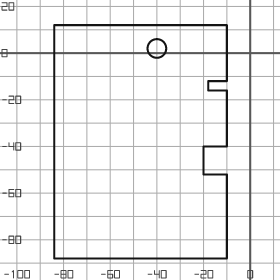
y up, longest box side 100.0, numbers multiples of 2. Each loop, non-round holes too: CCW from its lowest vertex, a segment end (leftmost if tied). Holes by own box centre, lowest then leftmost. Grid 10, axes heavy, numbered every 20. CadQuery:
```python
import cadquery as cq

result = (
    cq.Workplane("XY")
    .moveTo(-84.0, -88.0)
    .lineTo(-10.0, -88.0)
    .lineTo(-10.0, -52.0)
    .lineTo(-20.0, -52.0)
    .lineTo(-20.0, -40.0)
    .lineTo(-10.0, -40.0)
    .lineTo(-10.0, -16.0)
    .lineTo(-18.0, -16.0)
    .lineTo(-18.0, -12.0)
    .lineTo(-10.0, -12.0)
    .lineTo(-10.0, 12.0)
    .lineTo(-84.0, 12.0)
    .close()
    .moveTo(-40.0, 2.0)
    .circle(4.0)
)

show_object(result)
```